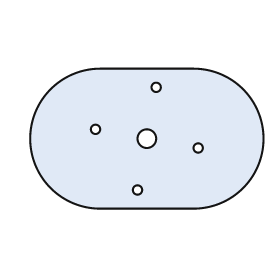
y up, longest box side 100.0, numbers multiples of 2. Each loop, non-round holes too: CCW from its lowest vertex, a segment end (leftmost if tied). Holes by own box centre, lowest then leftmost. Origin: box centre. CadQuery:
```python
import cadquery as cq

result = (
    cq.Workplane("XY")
    .moveTo(-20.0, -30.0)
    .lineTo(20.0, -30.0)
    .threePointArc((50.0, 0.0), (20.0, 30.0))
    .lineTo(-20.0, 30.0)
    .threePointArc((-50.0, 0.0), (-20.0, -30.0))
    .close()
    .moveTo(-4.0, -22.0)
    .circle(2.0)
    .moveTo(22.0, -4.0)
    .circle(2.0)
    .moveTo(0.0, 0.0)
    .circle(4.0)
    .moveTo(-22.0, 4.0)
    .circle(2.0)
    .moveTo(4.0, 22.0)
    .circle(2.0)
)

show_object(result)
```